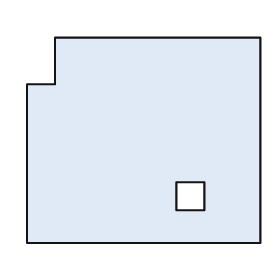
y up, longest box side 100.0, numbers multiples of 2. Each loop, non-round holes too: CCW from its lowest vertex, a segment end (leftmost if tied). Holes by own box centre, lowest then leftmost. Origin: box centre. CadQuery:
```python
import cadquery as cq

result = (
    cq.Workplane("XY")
    .moveTo(-50.0, -44.0)
    .lineTo(50.0, -44.0)
    .lineTo(50.0, 44.0)
    .lineTo(-38.0, 44.0)
    .lineTo(-38.0, 24.0)
    .lineTo(-50.0, 24.0)
    .close()
    .moveTo(14.0, -30.0)
    .lineTo(26.0, -30.0)
    .lineTo(26.0, -18.0)
    .lineTo(14.0, -18.0)
    .close()
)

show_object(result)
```